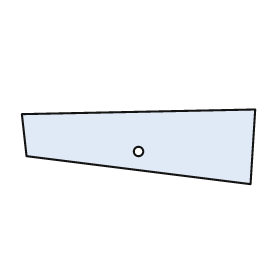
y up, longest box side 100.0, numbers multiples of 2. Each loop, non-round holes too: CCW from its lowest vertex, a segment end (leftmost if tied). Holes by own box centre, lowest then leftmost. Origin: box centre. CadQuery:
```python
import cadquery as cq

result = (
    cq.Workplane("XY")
    .moveTo(48.0, -16.0)
    .lineTo(50.0, 16.0)
    .lineTo(-50.0, 14.0)
    .lineTo(-48.0, -4.0)
    .close()
    .moveTo(0.0, -2.0)
    .circle(2.0)
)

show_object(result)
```